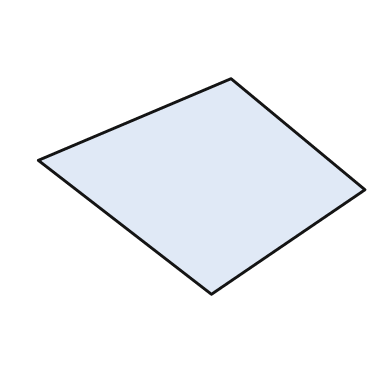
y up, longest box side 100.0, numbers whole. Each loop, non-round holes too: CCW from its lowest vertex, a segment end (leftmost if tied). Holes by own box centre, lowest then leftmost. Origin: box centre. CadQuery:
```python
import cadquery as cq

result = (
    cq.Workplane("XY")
    .moveTo(3.0, -33.0)
    .lineTo(50.0, -1.0)
    .lineTo(9.0, 33.0)
    .lineTo(-50.0, 8.0)
    .close()
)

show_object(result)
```